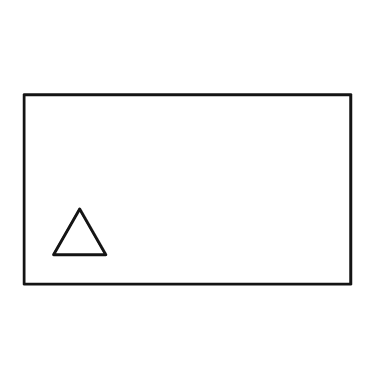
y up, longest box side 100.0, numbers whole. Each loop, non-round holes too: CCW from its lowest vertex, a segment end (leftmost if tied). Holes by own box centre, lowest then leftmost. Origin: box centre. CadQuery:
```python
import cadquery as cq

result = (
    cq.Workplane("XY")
    .moveTo(-50.0, -29.0)
    .lineTo(50.0, -29.0)
    .lineTo(50.0, 29.0)
    .lineTo(-50.0, 29.0)
    .close()
    .moveTo(-41.0, -20.0)
    .lineTo(-25.0, -20.0)
    .lineTo(-33.0, -6.0)
    .close()
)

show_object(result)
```